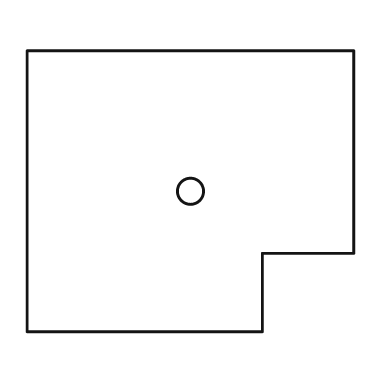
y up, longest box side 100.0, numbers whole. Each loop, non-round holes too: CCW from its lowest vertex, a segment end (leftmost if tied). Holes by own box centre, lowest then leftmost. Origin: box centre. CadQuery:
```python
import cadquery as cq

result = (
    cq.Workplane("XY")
    .moveTo(-50.0, -43.0)
    .lineTo(22.0, -43.0)
    .lineTo(22.0, -19.0)
    .lineTo(50.0, -19.0)
    .lineTo(50.0, 43.0)
    .lineTo(-50.0, 43.0)
    .close()
    .moveTo(0.0, 0.0)
    .circle(4.0)
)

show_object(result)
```